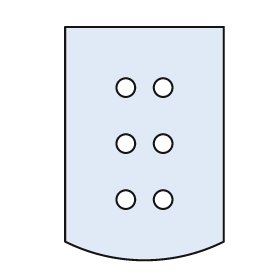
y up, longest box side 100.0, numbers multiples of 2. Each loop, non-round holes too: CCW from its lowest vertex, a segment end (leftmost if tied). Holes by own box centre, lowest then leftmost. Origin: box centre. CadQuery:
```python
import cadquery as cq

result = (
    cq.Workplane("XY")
    .moveTo(-34.0, -42.0)
    .threePointArc((0.0, -50.0), (34.0, -42.0))
    .lineTo(34.0, 50.0)
    .lineTo(-34.0, 50.0)
    .close()
    .moveTo(-8.0, -24.0)
    .circle(4.0)
    .moveTo(8.0, -24.0)
    .circle(4.0)
    .moveTo(-8.0, 0.0)
    .circle(4.0)
    .moveTo(8.0, 0.0)
    .circle(4.0)
    .moveTo(-8.0, 24.0)
    .circle(4.0)
    .moveTo(8.0, 24.0)
    .circle(4.0)
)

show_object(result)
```